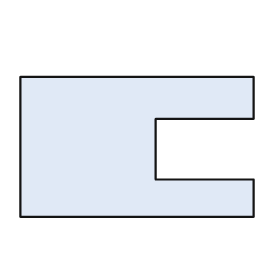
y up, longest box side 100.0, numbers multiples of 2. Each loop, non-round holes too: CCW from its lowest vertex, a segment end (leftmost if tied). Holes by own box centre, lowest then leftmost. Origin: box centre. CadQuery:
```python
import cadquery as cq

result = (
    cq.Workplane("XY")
    .moveTo(-50.0, -30.0)
    .lineTo(50.0, -30.0)
    .lineTo(50.0, -14.0)
    .lineTo(8.0, -14.0)
    .lineTo(8.0, 12.0)
    .lineTo(50.0, 12.0)
    .lineTo(50.0, 30.0)
    .lineTo(-50.0, 30.0)
    .close()
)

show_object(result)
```